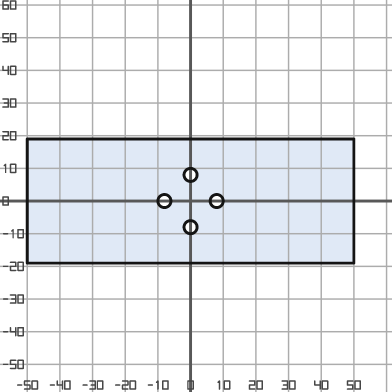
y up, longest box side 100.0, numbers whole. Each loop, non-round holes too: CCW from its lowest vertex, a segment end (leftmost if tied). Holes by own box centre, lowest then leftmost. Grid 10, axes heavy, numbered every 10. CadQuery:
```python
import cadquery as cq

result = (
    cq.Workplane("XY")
    .moveTo(-50.0, -19.0)
    .lineTo(50.0, -19.0)
    .lineTo(50.0, 19.0)
    .lineTo(-50.0, 19.0)
    .close()
    .moveTo(0.0, -8.0)
    .circle(2.0)
    .moveTo(-8.0, 0.0)
    .circle(2.0)
    .moveTo(8.0, 0.0)
    .circle(2.0)
    .moveTo(0.0, 8.0)
    .circle(2.0)
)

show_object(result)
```